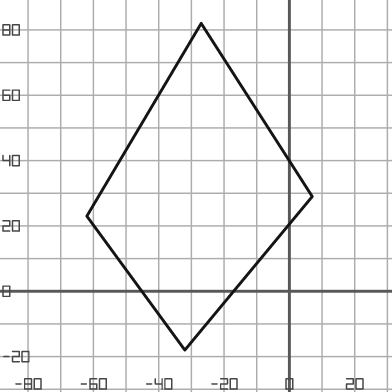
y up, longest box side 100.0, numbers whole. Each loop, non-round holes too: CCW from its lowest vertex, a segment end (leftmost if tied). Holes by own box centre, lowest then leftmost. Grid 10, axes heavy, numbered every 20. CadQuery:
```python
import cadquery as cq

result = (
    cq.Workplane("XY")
    .moveTo(-32.0, -18.0)
    .lineTo(7.0, 29.0)
    .lineTo(-27.0, 82.0)
    .lineTo(-62.0, 23.0)
    .close()
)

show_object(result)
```